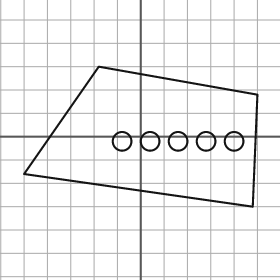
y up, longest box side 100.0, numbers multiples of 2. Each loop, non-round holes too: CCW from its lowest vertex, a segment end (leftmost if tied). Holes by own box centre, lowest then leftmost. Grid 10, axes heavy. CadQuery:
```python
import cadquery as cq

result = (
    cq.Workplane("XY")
    .moveTo(48.0, -30.0)
    .lineTo(50.0, 18.0)
    .lineTo(-18.0, 30.0)
    .lineTo(-50.0, -16.0)
    .close()
    .moveTo(-8.0, -2.0)
    .circle(4.0)
    .moveTo(4.0, -2.0)
    .circle(4.0)
    .moveTo(16.0, -2.0)
    .circle(4.0)
    .moveTo(28.0, -2.0)
    .circle(4.0)
    .moveTo(40.0, -2.0)
    .circle(4.0)
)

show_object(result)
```